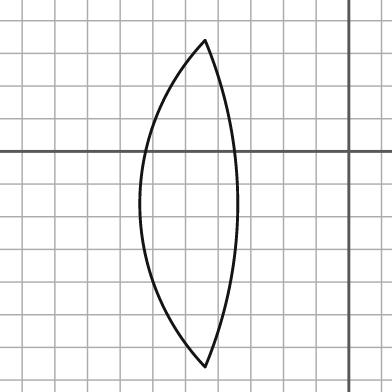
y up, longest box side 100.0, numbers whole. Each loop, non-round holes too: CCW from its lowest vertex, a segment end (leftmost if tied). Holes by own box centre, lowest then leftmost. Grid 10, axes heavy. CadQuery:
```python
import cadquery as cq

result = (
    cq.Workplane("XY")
    .moveTo(-44.0, -66.0)
    .threePointArc((-34.0, -16.0), (-44.0, 34.0))
    .threePointArc((-64.0, -16.0), (-44.0, -66.0))
    .close()
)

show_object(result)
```